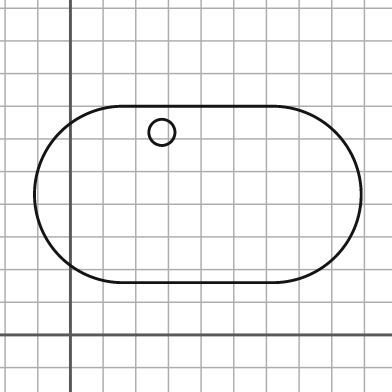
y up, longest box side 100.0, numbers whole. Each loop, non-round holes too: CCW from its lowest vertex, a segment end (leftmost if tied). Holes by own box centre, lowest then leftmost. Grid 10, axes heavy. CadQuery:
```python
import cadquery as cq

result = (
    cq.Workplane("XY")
    .moveTo(16.0, 16.0)
    .lineTo(62.0, 16.0)
    .threePointArc((89.0, 43.0), (62.0, 70.0))
    .lineTo(16.0, 70.0)
    .threePointArc((-11.0, 43.0), (16.0, 16.0))
    .close()
    .moveTo(28.0, 62.0)
    .circle(4.0)
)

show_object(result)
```